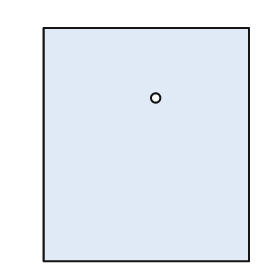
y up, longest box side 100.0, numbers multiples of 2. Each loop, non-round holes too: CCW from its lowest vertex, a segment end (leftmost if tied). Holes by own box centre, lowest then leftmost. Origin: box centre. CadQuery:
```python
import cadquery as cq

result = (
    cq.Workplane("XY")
    .moveTo(-44.0, -50.0)
    .lineTo(44.0, -50.0)
    .lineTo(44.0, 50.0)
    .lineTo(-44.0, 50.0)
    .close()
    .moveTo(4.0, 20.0)
    .circle(2.0)
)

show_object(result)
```